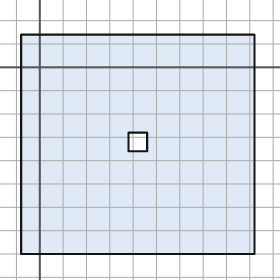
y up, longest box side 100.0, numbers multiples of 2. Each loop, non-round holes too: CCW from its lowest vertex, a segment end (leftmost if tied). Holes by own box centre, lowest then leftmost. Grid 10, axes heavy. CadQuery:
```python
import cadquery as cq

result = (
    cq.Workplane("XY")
    .moveTo(-8.0, -80.0)
    .lineTo(92.0, -80.0)
    .lineTo(92.0, 14.0)
    .lineTo(-8.0, 14.0)
    .close()
    .moveTo(38.0, -36.0)
    .lineTo(46.0, -36.0)
    .lineTo(46.0, -28.0)
    .lineTo(38.0, -28.0)
    .close()
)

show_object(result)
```